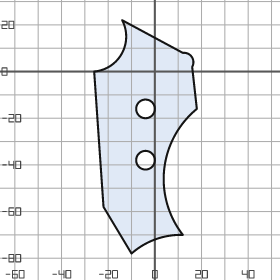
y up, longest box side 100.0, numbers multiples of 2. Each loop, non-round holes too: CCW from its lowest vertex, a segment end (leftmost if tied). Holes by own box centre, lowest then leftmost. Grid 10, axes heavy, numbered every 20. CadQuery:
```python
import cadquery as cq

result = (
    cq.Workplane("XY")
    .moveTo(-10.0, -78.0)
    .threePointArc((0.0, -72.0), (12.0, -70.0))
    .threePointArc((4.0, -42.0), (18.0, -16.0))
    .lineTo(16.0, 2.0)
    .threePointArc((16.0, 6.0), (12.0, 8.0))
    .lineTo(-14.0, 22.0)
    .threePointArc((-14.0, 8.0), (-26.0, 0.0))
    .lineTo(-22.0, -58.0)
    .close()
    .moveTo(-4.0, -38.0)
    .circle(4.0)
    .moveTo(-4.0, -16.0)
    .circle(4.0)
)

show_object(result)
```